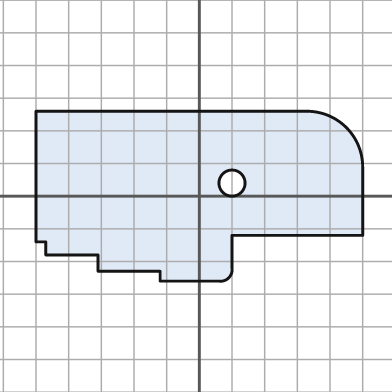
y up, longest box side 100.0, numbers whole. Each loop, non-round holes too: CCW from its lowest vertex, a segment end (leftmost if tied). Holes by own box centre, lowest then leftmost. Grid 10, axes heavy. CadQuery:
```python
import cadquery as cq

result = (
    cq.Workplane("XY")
    .moveTo(-12.0, -26.0)
    .lineTo(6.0, -26.0)
    .threePointArc((9.0, -25.0), (10.0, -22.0))
    .lineTo(10.0, -12.0)
    .lineTo(50.0, -12.0)
    .lineTo(50.0, 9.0)
    .threePointArc((45.0, 21.0), (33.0, 26.0))
    .lineTo(-50.0, 26.0)
    .lineTo(-50.0, -14.0)
    .lineTo(-47.0, -14.0)
    .lineTo(-47.0, -18.0)
    .lineTo(-31.0, -18.0)
    .lineTo(-31.0, -23.0)
    .lineTo(-12.0, -23.0)
    .close()
    .moveTo(10.0, 4.0)
    .circle(4.0)
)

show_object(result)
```